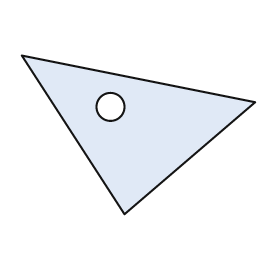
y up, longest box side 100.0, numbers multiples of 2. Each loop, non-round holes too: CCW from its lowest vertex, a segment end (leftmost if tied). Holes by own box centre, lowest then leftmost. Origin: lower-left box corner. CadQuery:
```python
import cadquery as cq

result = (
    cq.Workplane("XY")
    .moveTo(44.0, 0.0)
    .lineTo(100.0, 48.0)
    .lineTo(0.0, 68.0)
    .close()
    .moveTo(38.0, 46.0)
    .circle(6.0)
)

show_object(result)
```